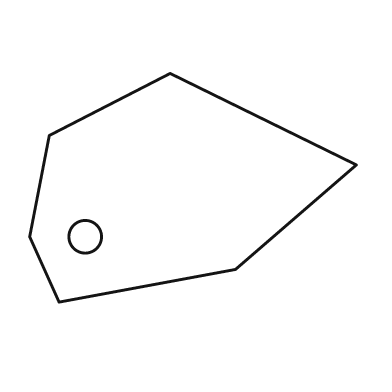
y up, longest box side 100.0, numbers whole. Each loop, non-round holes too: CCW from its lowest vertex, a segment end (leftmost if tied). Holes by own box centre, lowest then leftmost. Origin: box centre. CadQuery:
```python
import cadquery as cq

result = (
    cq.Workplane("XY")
    .moveTo(-41.0, -35.0)
    .lineTo(13.0, -25.0)
    .lineTo(50.0, 7.0)
    .lineTo(-7.0, 35.0)
    .lineTo(-44.0, 16.0)
    .lineTo(-50.0, -15.0)
    .close()
    .moveTo(-33.0, -15.0)
    .circle(5.0)
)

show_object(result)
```